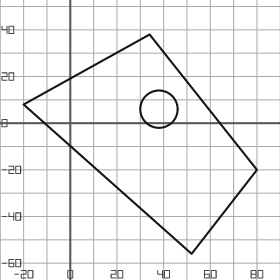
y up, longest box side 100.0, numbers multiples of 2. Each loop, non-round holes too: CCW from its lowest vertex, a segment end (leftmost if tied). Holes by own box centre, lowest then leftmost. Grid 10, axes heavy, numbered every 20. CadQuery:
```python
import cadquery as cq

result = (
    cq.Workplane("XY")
    .moveTo(52.0, -56.0)
    .lineTo(80.0, -20.0)
    .lineTo(34.0, 38.0)
    .lineTo(-20.0, 8.0)
    .close()
    .moveTo(38.0, 6.0)
    .circle(8.0)
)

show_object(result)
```